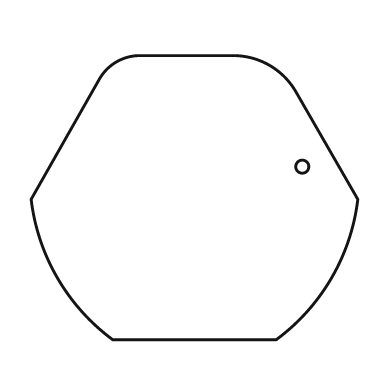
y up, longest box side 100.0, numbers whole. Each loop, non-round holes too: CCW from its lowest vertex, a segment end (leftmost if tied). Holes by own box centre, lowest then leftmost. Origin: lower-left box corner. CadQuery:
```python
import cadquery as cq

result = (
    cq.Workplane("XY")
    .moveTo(25.0, 0.0)
    .lineTo(75.0, 0.0)
    .threePointArc((92.0, 19.0), (100.0, 43.0))
    .lineTo(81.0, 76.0)
    .threePointArc((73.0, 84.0), (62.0, 87.0))
    .lineTo(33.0, 87.0)
    .threePointArc((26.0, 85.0), (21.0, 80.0))
    .lineTo(0.0, 43.0)
    .threePointArc((8.0, 19.0), (25.0, 0.0))
    .close()
    .moveTo(83.0, 53.0)
    .circle(2.0)
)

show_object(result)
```